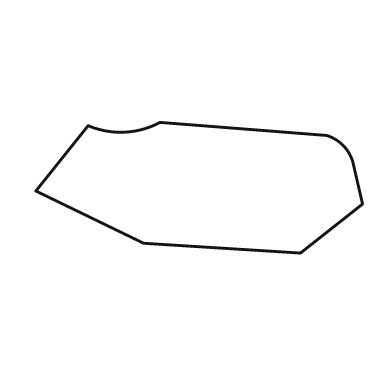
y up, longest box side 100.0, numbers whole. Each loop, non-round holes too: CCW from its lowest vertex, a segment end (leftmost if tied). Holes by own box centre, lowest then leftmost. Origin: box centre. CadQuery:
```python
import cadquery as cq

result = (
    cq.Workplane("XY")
    .moveTo(31.0, -20.0)
    .lineTo(50.0, -5.0)
    .lineTo(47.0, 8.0)
    .threePointArc((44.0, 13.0), (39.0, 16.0))
    .lineTo(-12.0, 20.0)
    .threePointArc((-23.0, 17.0), (-34.0, 19.0))
    .lineTo(-50.0, -1.0)
    .lineTo(-17.0, -17.0)
    .close()
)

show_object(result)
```